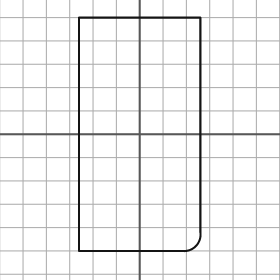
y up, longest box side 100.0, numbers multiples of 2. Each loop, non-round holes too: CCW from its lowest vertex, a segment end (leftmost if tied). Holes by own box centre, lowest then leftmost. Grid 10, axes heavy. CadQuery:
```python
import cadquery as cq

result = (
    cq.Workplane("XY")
    .moveTo(-26.0, -50.0)
    .lineTo(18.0, -50.0)
    .threePointArc((24.0, -48.0), (26.0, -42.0))
    .lineTo(26.0, 50.0)
    .lineTo(-26.0, 50.0)
    .close()
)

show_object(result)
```